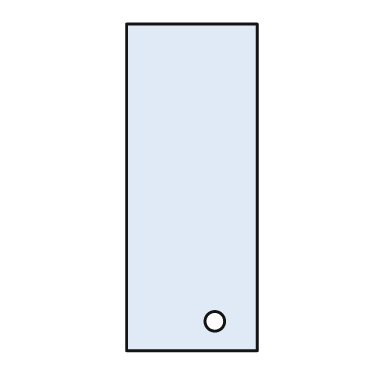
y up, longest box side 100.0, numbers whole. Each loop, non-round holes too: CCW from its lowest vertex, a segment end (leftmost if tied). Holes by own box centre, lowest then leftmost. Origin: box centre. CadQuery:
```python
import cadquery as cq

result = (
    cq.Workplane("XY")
    .moveTo(-20.0, -50.0)
    .lineTo(20.0, -50.0)
    .lineTo(20.0, 50.0)
    .lineTo(-20.0, 50.0)
    .close()
    .moveTo(7.0, -41.0)
    .circle(3.0)
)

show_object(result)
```